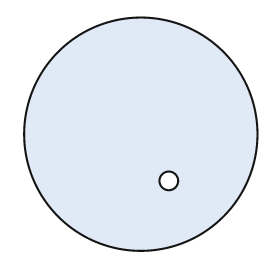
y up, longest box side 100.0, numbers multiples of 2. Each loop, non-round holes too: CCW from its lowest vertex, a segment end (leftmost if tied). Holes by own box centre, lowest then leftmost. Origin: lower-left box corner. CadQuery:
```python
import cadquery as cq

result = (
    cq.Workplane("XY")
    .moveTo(50.0, 50.0)
    .circle(50.0)
    .moveTo(62.0, 30.0)
    .circle(4.0)
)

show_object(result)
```